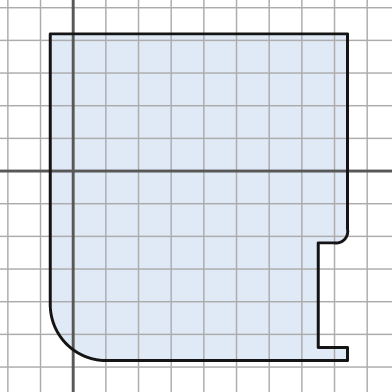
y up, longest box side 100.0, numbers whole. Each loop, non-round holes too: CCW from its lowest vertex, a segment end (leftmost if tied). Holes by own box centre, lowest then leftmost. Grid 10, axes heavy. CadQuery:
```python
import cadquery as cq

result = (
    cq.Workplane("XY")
    .moveTo(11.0, -58.0)
    .lineTo(84.0, -58.0)
    .lineTo(84.0, -54.0)
    .lineTo(75.0, -54.0)
    .lineTo(75.0, -22.0)
    .lineTo(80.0, -22.0)
    .threePointArc((83.0, -21.0), (84.0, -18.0))
    .lineTo(84.0, 42.0)
    .lineTo(-7.0, 42.0)
    .lineTo(-7.0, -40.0)
    .threePointArc((-2.0, -53.0), (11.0, -58.0))
    .close()
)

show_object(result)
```